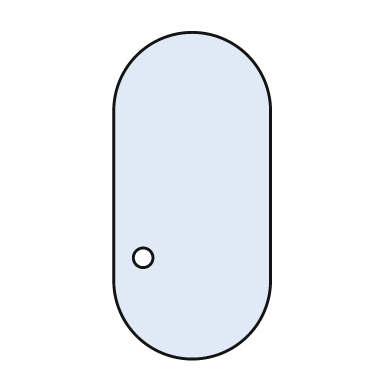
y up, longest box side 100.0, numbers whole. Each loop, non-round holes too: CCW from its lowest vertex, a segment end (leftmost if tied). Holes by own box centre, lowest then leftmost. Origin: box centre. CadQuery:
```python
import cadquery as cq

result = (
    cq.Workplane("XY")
    .moveTo(-24.0, -26.0)
    .threePointArc((0.0, -50.0), (24.0, -26.0))
    .lineTo(24.0, 26.0)
    .threePointArc((0.0, 50.0), (-24.0, 26.0))
    .close()
    .moveTo(-15.0, -19.0)
    .circle(3.0)
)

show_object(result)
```